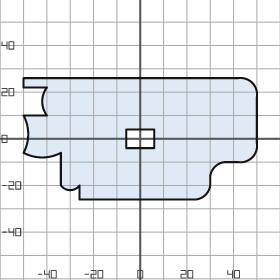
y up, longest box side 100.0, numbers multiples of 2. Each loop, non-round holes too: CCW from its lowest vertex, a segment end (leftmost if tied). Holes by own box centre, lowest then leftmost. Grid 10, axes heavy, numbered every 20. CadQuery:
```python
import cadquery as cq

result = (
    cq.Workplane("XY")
    .moveTo(-26.0, -26.0)
    .lineTo(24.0, -26.0)
    .threePointArc((28.0, -24.0), (30.0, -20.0))
    .lineTo(30.0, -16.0)
    .threePointArc((32.0, -12.0), (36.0, -10.0))
    .lineTo(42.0, -10.0)
    .threePointArc((48.0, -8.0), (50.0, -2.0))
    .lineTo(50.0, 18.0)
    .threePointArc((48.0, 24.0), (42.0, 26.0))
    .lineTo(-50.0, 26.0)
    .lineTo(-50.0, 22.0)
    .lineTo(-40.0, 22.0)
    .threePointArc((-42.0, 16.0), (-40.0, 10.0))
    .lineTo(-50.0, 10.0)
    .threePointArc((-48.0, 2.0), (-50.0, -6.0))
    .threePointArc((-42.0, -8.0), (-34.0, -6.0))
    .lineTo(-34.0, -20.0)
    .threePointArc((-30.0, -22.0), (-26.0, -20.0))
    .close()
    .moveTo(-6.0, -4.0)
    .lineTo(6.0, -4.0)
    .lineTo(6.0, 4.0)
    .lineTo(-6.0, 4.0)
    .close()
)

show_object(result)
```